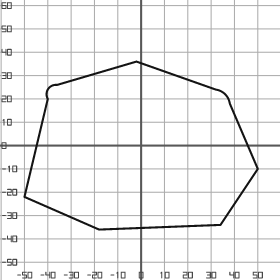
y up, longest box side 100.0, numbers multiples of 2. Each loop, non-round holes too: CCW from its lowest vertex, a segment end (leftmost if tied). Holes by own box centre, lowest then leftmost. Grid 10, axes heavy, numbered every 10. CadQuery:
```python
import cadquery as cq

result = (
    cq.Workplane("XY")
    .moveTo(-18.0, -36.0)
    .lineTo(34.0, -34.0)
    .lineTo(50.0, -10.0)
    .lineTo(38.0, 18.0)
    .threePointArc((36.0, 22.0), (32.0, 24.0))
    .lineTo(-2.0, 36.0)
    .lineTo(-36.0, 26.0)
    .threePointArc((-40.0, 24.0), (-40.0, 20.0))
    .lineTo(-50.0, -22.0)
    .close()
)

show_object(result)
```